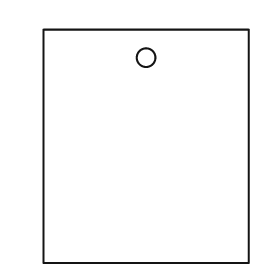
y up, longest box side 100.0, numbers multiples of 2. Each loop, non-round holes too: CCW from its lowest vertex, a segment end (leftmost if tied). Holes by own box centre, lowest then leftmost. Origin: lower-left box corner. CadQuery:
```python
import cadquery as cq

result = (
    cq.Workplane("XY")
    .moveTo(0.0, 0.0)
    .lineTo(88.0, 0.0)
    .lineTo(88.0, 100.0)
    .lineTo(0.0, 100.0)
    .close()
    .moveTo(44.0, 88.0)
    .circle(4.0)
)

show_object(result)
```